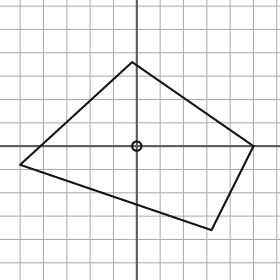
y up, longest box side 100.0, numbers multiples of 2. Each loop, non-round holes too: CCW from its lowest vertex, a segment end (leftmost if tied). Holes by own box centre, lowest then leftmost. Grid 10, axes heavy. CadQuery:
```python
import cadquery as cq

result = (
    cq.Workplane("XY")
    .moveTo(32.0, -36.0)
    .lineTo(50.0, 0.0)
    .lineTo(-2.0, 36.0)
    .lineTo(-50.0, -8.0)
    .close()
    .moveTo(0.0, 0.0)
    .circle(2.0)
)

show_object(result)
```